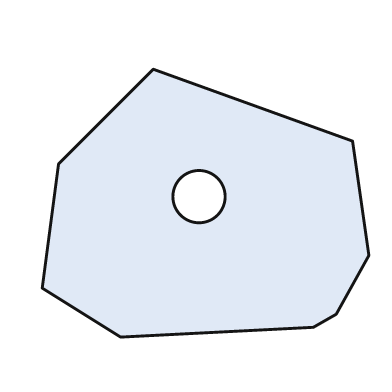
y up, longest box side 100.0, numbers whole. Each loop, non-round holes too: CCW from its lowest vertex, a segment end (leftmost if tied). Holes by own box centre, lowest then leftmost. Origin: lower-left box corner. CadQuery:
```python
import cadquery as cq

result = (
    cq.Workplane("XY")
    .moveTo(24.0, 0.0)
    .lineTo(83.0, 3.0)
    .lineTo(90.0, 7.0)
    .lineTo(100.0, 25.0)
    .lineTo(95.0, 60.0)
    .lineTo(34.0, 82.0)
    .lineTo(5.0, 53.0)
    .lineTo(0.0, 15.0)
    .close()
    .moveTo(48.0, 43.0)
    .circle(8.0)
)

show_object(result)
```